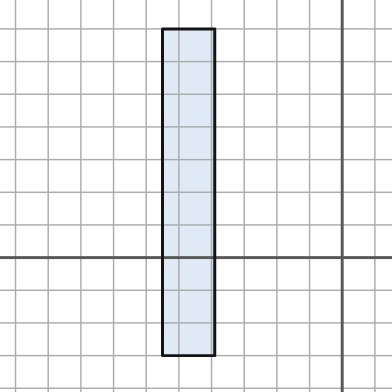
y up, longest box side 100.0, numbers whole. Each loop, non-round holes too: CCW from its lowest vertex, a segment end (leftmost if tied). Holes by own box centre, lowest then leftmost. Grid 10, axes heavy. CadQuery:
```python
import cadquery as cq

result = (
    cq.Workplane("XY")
    .moveTo(-55.0, -30.0)
    .lineTo(-39.0, -30.0)
    .lineTo(-39.0, 70.0)
    .lineTo(-55.0, 70.0)
    .close()
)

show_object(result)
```